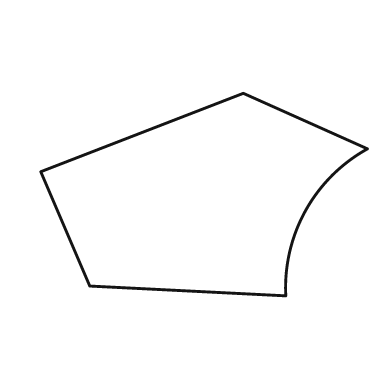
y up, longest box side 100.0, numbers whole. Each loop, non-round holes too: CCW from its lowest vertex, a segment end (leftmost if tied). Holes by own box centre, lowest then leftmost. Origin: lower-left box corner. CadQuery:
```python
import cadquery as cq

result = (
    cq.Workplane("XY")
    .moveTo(75.0, 0.0)
    .threePointArc((81.0, 26.0), (100.0, 45.0))
    .lineTo(62.0, 62.0)
    .lineTo(0.0, 38.0)
    .lineTo(15.0, 3.0)
    .close()
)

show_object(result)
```